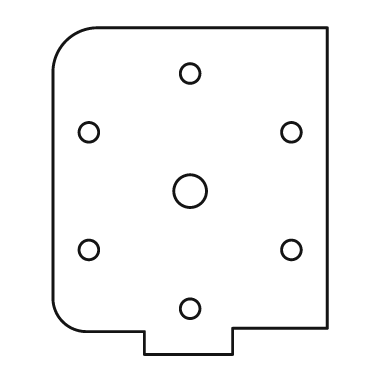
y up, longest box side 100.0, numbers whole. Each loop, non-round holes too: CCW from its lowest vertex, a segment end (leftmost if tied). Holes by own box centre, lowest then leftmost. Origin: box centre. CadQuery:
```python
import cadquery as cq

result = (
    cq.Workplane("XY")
    .moveTo(-14.0, -50.0)
    .lineTo(13.0, -50.0)
    .lineTo(13.0, -42.0)
    .lineTo(42.0, -42.0)
    .lineTo(42.0, 50.0)
    .lineTo(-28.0, 50.0)
    .threePointArc((-38.0, 46.0), (-42.0, 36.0))
    .lineTo(-42.0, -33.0)
    .threePointArc((-39.0, -40.0), (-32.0, -43.0))
    .lineTo(-14.0, -43.0)
    .close()
    .moveTo(0.0, -36.0)
    .circle(3.0)
    .moveTo(-31.0, -18.0)
    .circle(3.0)
    .moveTo(31.0, -18.0)
    .circle(3.0)
    .moveTo(0.0, 0.0)
    .circle(5.0)
    .moveTo(-31.0, 18.0)
    .circle(3.0)
    .moveTo(31.0, 18.0)
    .circle(3.0)
    .moveTo(0.0, 36.0)
    .circle(3.0)
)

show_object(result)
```